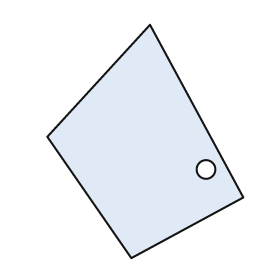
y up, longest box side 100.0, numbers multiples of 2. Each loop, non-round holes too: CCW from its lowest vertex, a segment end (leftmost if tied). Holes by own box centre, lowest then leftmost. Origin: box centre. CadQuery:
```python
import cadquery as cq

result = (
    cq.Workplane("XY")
    .moveTo(-6.0, -50.0)
    .lineTo(42.0, -24.0)
    .lineTo(2.0, 50.0)
    .lineTo(-42.0, 2.0)
    .close()
    .moveTo(26.0, -12.0)
    .circle(4.0)
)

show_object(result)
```